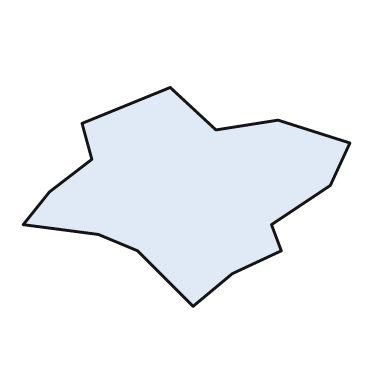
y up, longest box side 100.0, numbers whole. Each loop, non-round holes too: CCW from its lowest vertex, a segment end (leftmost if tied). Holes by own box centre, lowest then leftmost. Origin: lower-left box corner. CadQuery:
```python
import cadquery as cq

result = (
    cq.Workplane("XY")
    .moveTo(52.0, 0.0)
    .lineTo(64.0, 10.0)
    .lineTo(79.0, 17.0)
    .lineTo(76.0, 25.0)
    .lineTo(94.0, 37.0)
    .lineTo(100.0, 50.0)
    .lineTo(78.0, 57.0)
    .lineTo(59.0, 54.0)
    .lineTo(45.0, 67.0)
    .lineTo(18.0, 56.0)
    .lineTo(21.0, 45.0)
    .lineTo(8.0, 35.0)
    .lineTo(0.0, 25.0)
    .lineTo(23.0, 22.0)
    .lineTo(35.0, 17.0)
    .close()
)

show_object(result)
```